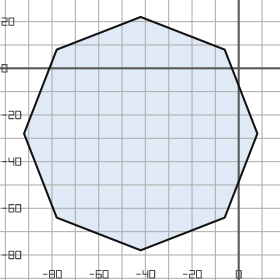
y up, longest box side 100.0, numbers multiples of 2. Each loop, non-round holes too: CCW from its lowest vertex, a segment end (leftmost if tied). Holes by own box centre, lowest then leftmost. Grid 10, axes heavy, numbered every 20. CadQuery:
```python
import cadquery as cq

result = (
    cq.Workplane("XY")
    .moveTo(-42.0, -78.0)
    .lineTo(-6.0, -64.0)
    .lineTo(8.0, -28.0)
    .lineTo(-6.0, 8.0)
    .lineTo(-42.0, 22.0)
    .lineTo(-78.0, 8.0)
    .lineTo(-92.0, -28.0)
    .lineTo(-78.0, -64.0)
    .close()
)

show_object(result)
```